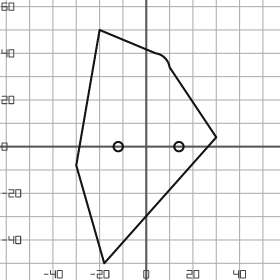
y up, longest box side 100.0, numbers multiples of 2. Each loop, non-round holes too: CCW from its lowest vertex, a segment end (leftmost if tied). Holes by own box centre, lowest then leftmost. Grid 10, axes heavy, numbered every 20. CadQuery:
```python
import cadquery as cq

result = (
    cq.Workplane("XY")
    .moveTo(-18.0, -50.0)
    .lineTo(30.0, 4.0)
    .lineTo(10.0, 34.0)
    .threePointArc((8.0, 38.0), (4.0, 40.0))
    .lineTo(-20.0, 50.0)
    .lineTo(-30.0, -8.0)
    .close()
    .moveTo(-12.0, 0.0)
    .circle(2.0)
    .moveTo(14.0, 0.0)
    .circle(2.0)
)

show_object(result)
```